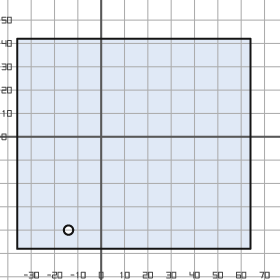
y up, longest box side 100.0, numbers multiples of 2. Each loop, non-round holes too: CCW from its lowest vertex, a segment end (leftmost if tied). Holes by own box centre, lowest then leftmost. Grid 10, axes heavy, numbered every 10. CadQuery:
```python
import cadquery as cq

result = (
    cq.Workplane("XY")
    .moveTo(-36.0, -48.0)
    .lineTo(64.0, -48.0)
    .lineTo(64.0, 42.0)
    .lineTo(-36.0, 42.0)
    .close()
    .moveTo(-14.0, -40.0)
    .circle(2.0)
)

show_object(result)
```